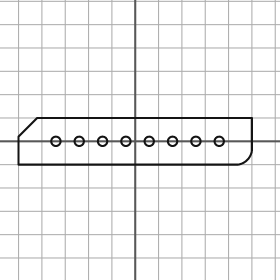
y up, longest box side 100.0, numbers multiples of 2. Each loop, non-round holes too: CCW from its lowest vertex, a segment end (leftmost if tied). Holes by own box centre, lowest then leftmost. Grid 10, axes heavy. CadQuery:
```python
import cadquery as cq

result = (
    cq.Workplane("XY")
    .moveTo(-50.0, -10.0)
    .lineTo(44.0, -10.0)
    .threePointArc((48.0, -8.0), (50.0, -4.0))
    .lineTo(50.0, 10.0)
    .lineTo(-42.0, 10.0)
    .lineTo(-50.0, 2.0)
    .close()
    .moveTo(-34.0, 0.0)
    .circle(2.0)
    .moveTo(-24.0, 0.0)
    .circle(2.0)
    .moveTo(-14.0, 0.0)
    .circle(2.0)
    .moveTo(-4.0, 0.0)
    .circle(2.0)
    .moveTo(6.0, 0.0)
    .circle(2.0)
    .moveTo(16.0, 0.0)
    .circle(2.0)
    .moveTo(26.0, 0.0)
    .circle(2.0)
    .moveTo(36.0, 0.0)
    .circle(2.0)
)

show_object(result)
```